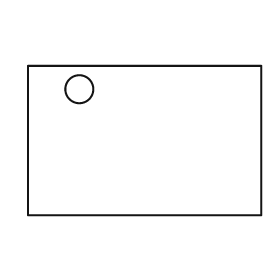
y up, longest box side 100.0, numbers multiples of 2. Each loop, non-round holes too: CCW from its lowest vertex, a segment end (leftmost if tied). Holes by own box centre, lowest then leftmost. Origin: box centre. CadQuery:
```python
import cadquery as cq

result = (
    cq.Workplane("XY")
    .moveTo(-50.0, -32.0)
    .lineTo(50.0, -32.0)
    .lineTo(50.0, 32.0)
    .lineTo(-50.0, 32.0)
    .close()
    .moveTo(-28.0, 22.0)
    .circle(6.0)
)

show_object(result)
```